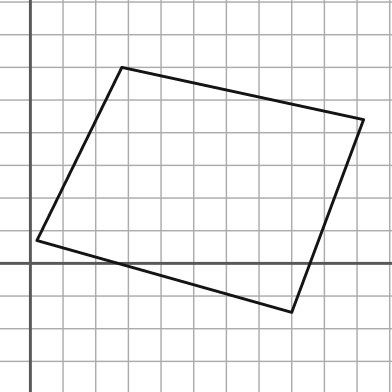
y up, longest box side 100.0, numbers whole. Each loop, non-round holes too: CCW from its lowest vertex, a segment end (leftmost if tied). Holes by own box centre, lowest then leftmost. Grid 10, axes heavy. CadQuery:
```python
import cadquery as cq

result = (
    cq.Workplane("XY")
    .moveTo(80.0, -15.0)
    .lineTo(102.0, 44.0)
    .lineTo(28.0, 60.0)
    .lineTo(2.0, 7.0)
    .close()
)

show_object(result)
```